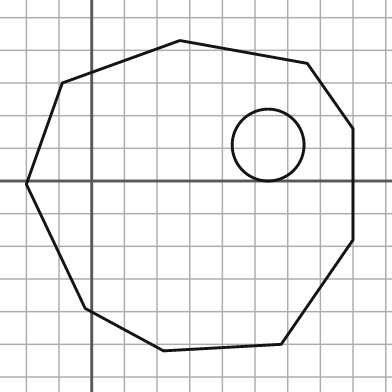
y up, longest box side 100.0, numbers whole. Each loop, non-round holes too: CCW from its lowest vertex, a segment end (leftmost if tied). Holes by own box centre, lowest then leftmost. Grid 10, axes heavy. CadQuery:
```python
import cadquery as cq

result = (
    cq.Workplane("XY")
    .moveTo(22.0, -52.0)
    .lineTo(58.0, -50.0)
    .lineTo(80.0, -18.0)
    .lineTo(80.0, 16.0)
    .lineTo(66.0, 36.0)
    .lineTo(27.0, 43.0)
    .lineTo(-9.0, 30.0)
    .lineTo(-20.0, -1.0)
    .lineTo(-2.0, -39.0)
    .close()
    .moveTo(54.0, 11.0)
    .circle(11.0)
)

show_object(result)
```